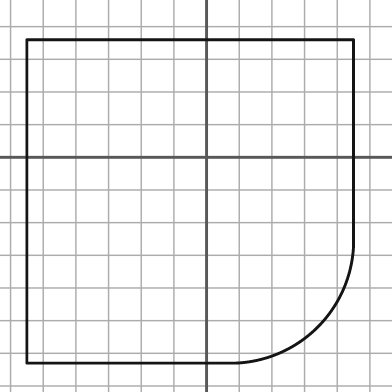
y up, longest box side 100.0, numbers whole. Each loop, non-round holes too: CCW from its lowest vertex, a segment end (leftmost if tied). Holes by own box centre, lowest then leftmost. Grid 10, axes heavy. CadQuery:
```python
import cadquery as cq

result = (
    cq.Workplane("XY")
    .moveTo(-55.0, -63.0)
    .lineTo(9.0, -63.0)
    .threePointArc((34.0, -52.0), (45.0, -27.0))
    .lineTo(45.0, 36.0)
    .lineTo(-55.0, 36.0)
    .close()
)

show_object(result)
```